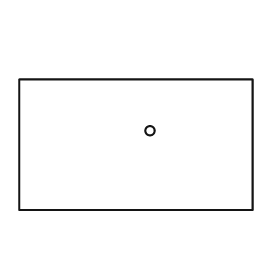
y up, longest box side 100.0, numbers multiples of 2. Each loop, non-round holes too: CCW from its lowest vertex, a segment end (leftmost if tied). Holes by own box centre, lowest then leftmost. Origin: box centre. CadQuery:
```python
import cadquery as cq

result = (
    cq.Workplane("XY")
    .moveTo(-50.0, -28.0)
    .lineTo(50.0, -28.0)
    .lineTo(50.0, 28.0)
    .lineTo(-50.0, 28.0)
    .close()
    .moveTo(6.0, 6.0)
    .circle(2.0)
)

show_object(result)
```